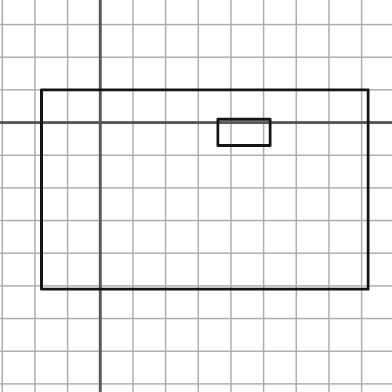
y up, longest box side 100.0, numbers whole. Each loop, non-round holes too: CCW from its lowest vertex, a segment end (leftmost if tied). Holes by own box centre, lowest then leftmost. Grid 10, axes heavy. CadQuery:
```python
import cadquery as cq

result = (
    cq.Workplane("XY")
    .moveTo(-18.0, -51.0)
    .lineTo(82.0, -51.0)
    .lineTo(82.0, 10.0)
    .lineTo(-18.0, 10.0)
    .close()
    .moveTo(36.0, -7.0)
    .lineTo(52.0, -7.0)
    .lineTo(52.0, 1.0)
    .lineTo(36.0, 1.0)
    .close()
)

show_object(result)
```